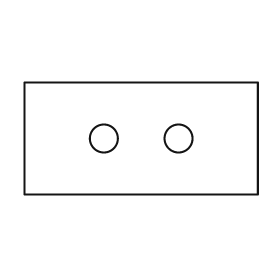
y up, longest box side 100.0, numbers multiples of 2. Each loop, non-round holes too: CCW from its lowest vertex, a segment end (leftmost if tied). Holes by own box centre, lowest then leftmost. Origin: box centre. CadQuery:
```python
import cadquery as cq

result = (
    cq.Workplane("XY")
    .moveTo(-50.0, -24.0)
    .lineTo(50.0, -24.0)
    .lineTo(50.0, 24.0)
    .lineTo(-50.0, 24.0)
    .close()
    .moveTo(-16.0, 0.0)
    .circle(6.0)
    .moveTo(16.0, 0.0)
    .circle(6.0)
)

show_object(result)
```